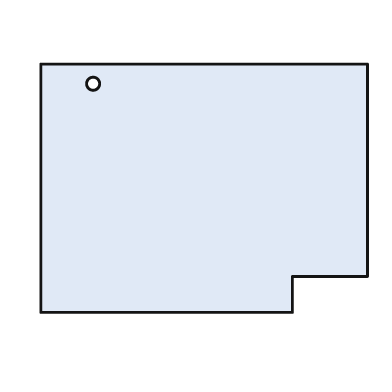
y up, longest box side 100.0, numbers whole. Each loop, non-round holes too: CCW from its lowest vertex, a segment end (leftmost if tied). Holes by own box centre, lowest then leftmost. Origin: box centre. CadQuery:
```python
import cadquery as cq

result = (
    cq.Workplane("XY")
    .moveTo(-50.0, -38.0)
    .lineTo(27.0, -38.0)
    .lineTo(27.0, -27.0)
    .lineTo(50.0, -27.0)
    .lineTo(50.0, 38.0)
    .lineTo(-50.0, 38.0)
    .close()
    .moveTo(-34.0, 32.0)
    .circle(2.0)
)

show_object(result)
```